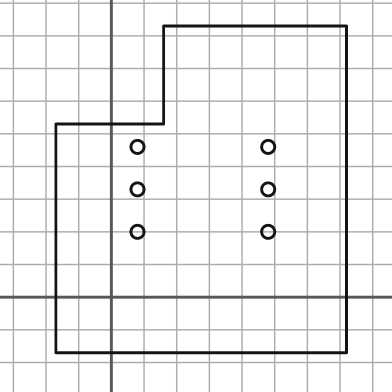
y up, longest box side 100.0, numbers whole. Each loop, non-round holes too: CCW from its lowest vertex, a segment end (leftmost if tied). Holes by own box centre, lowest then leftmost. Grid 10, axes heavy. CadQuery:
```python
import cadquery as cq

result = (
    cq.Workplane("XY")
    .moveTo(-17.0, -17.0)
    .lineTo(72.0, -17.0)
    .lineTo(72.0, 83.0)
    .lineTo(16.0, 83.0)
    .lineTo(16.0, 53.0)
    .lineTo(-17.0, 53.0)
    .close()
    .moveTo(8.0, 20.0)
    .circle(2.0)
    .moveTo(48.0, 20.0)
    .circle(2.0)
    .moveTo(8.0, 33.0)
    .circle(2.0)
    .moveTo(48.0, 33.0)
    .circle(2.0)
    .moveTo(8.0, 46.0)
    .circle(2.0)
    .moveTo(48.0, 46.0)
    .circle(2.0)
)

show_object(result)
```